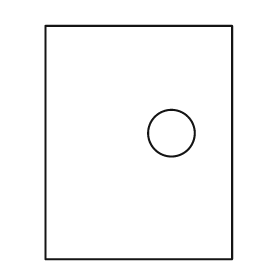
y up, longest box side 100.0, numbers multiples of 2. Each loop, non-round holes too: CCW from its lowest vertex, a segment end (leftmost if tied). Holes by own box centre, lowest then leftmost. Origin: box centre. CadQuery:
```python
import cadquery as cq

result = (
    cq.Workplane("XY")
    .moveTo(-40.0, -50.0)
    .lineTo(40.0, -50.0)
    .lineTo(40.0, 50.0)
    .lineTo(-40.0, 50.0)
    .close()
    .moveTo(14.0, 4.0)
    .circle(10.0)
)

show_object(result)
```